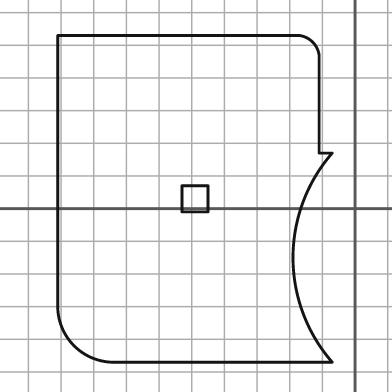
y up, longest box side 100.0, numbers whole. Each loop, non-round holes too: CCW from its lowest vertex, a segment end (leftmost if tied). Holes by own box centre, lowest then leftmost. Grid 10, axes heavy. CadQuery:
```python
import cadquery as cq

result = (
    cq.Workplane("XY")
    .moveTo(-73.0, -47.0)
    .lineTo(-7.0, -47.0)
    .threePointArc((-19.0, -15.0), (-7.0, 17.0))
    .lineTo(-11.0, 17.0)
    .lineTo(-11.0, 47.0)
    .threePointArc((-13.0, 51.0), (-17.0, 53.0))
    .lineTo(-91.0, 53.0)
    .lineTo(-91.0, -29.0)
    .threePointArc((-86.0, -42.0), (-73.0, -47.0))
    .close()
    .moveTo(-53.0, -1.0)
    .lineTo(-45.0, -1.0)
    .lineTo(-45.0, 7.0)
    .lineTo(-53.0, 7.0)
    .close()
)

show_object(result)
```